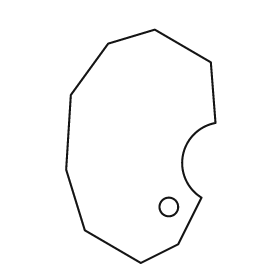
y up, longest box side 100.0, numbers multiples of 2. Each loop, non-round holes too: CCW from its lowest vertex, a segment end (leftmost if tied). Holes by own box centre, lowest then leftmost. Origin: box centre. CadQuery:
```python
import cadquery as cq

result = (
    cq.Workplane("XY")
    .moveTo(0.0, -50.0)
    .lineTo(16.0, -42.0)
    .lineTo(26.0, -22.0)
    .threePointArc((18.0, -4.0), (32.0, 10.0))
    .lineTo(30.0, 36.0)
    .lineTo(6.0, 50.0)
    .lineTo(-14.0, 44.0)
    .lineTo(-30.0, 22.0)
    .lineTo(-32.0, -10.0)
    .lineTo(-24.0, -36.0)
    .close()
    .moveTo(12.0, -26.0)
    .circle(4.0)
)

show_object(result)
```